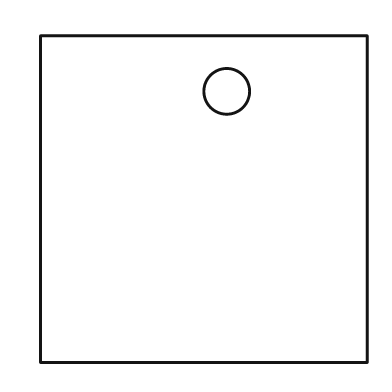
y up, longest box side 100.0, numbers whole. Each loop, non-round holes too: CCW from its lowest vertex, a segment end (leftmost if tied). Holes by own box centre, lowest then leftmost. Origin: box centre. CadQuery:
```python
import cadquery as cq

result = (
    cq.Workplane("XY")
    .moveTo(-50.0, -50.0)
    .lineTo(50.0, -50.0)
    .lineTo(50.0, 50.0)
    .lineTo(-50.0, 50.0)
    .close()
    .moveTo(7.0, 33.0)
    .circle(7.0)
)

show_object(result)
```